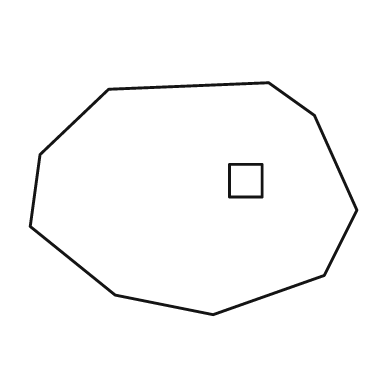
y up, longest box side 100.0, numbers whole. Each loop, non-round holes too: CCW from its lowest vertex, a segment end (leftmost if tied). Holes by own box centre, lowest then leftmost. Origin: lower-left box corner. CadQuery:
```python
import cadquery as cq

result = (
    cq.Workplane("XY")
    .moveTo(56.0, 0.0)
    .lineTo(90.0, 12.0)
    .lineTo(100.0, 32.0)
    .lineTo(87.0, 61.0)
    .lineTo(73.0, 71.0)
    .lineTo(24.0, 69.0)
    .lineTo(3.0, 49.0)
    .lineTo(0.0, 27.0)
    .lineTo(26.0, 6.0)
    .close()
    .moveTo(61.0, 36.0)
    .lineTo(71.0, 36.0)
    .lineTo(71.0, 46.0)
    .lineTo(61.0, 46.0)
    .close()
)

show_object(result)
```